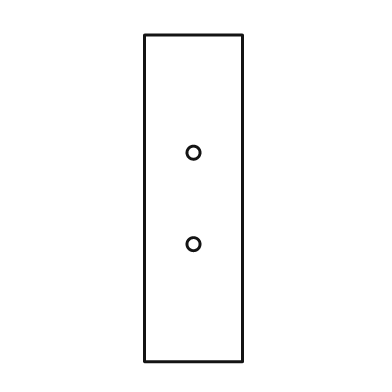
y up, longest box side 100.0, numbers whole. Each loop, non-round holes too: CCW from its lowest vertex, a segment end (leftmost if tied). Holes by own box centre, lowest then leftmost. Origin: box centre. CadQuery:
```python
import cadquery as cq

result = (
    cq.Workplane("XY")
    .moveTo(-15.0, -50.0)
    .lineTo(15.0, -50.0)
    .lineTo(15.0, 50.0)
    .lineTo(-15.0, 50.0)
    .close()
    .moveTo(0.0, -14.0)
    .circle(2.0)
    .moveTo(0.0, 14.0)
    .circle(2.0)
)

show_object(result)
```